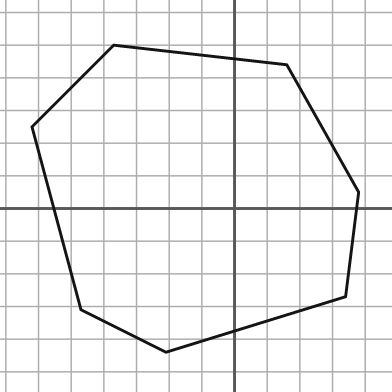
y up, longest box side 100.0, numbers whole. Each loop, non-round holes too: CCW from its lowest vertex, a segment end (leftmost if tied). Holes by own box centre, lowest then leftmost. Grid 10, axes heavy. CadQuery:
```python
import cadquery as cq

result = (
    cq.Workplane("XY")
    .moveTo(-21.0, -44.0)
    .lineTo(34.0, -27.0)
    .lineTo(38.0, 5.0)
    .lineTo(16.0, 44.0)
    .lineTo(-37.0, 50.0)
    .lineTo(-62.0, 25.0)
    .lineTo(-47.0, -31.0)
    .close()
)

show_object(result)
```